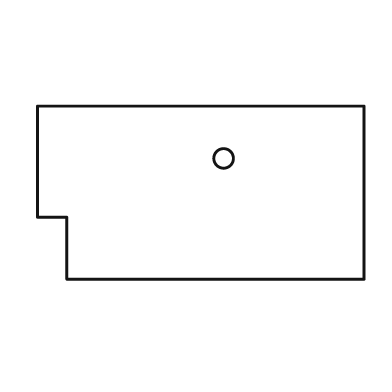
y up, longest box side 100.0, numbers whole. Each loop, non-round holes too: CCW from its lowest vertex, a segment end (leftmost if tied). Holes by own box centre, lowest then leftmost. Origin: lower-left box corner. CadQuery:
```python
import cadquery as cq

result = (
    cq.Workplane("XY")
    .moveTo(9.0, 0.0)
    .lineTo(100.0, 0.0)
    .lineTo(100.0, 53.0)
    .lineTo(0.0, 53.0)
    .lineTo(0.0, 19.0)
    .lineTo(9.0, 19.0)
    .close()
    .moveTo(57.0, 37.0)
    .circle(3.0)
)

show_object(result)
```